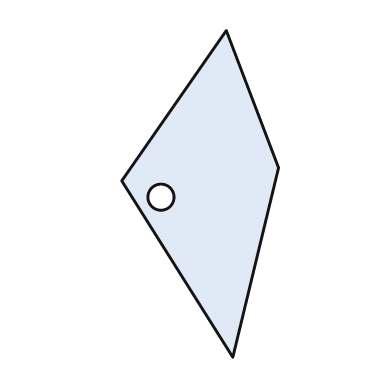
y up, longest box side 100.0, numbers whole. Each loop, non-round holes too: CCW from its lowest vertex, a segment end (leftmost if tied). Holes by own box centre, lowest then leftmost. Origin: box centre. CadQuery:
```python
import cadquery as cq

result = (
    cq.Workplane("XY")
    .moveTo(10.0, -50.0)
    .lineTo(24.0, 8.0)
    .lineTo(8.0, 50.0)
    .lineTo(-24.0, 4.0)
    .close()
    .moveTo(-12.0, -1.0)
    .circle(4.0)
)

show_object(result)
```